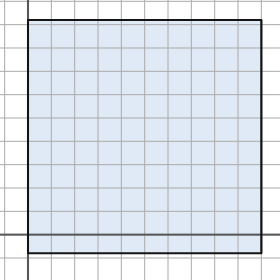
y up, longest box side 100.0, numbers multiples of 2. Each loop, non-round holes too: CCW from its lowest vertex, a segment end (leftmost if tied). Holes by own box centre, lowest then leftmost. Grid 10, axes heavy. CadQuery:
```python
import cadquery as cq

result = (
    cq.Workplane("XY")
    .moveTo(0.0, -8.0)
    .lineTo(100.0, -8.0)
    .lineTo(100.0, 92.0)
    .lineTo(0.0, 92.0)
    .close()
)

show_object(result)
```